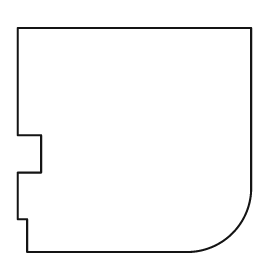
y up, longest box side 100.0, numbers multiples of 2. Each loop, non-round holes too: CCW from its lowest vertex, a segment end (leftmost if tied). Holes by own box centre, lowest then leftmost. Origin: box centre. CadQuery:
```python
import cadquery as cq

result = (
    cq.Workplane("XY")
    .moveTo(-46.0, -48.0)
    .lineTo(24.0, -48.0)
    .threePointArc((42.0, -40.0), (50.0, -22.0))
    .lineTo(50.0, 48.0)
    .lineTo(-50.0, 48.0)
    .lineTo(-50.0, 2.0)
    .lineTo(-40.0, 2.0)
    .lineTo(-40.0, -14.0)
    .lineTo(-50.0, -14.0)
    .lineTo(-50.0, -34.0)
    .lineTo(-46.0, -34.0)
    .close()
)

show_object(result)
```